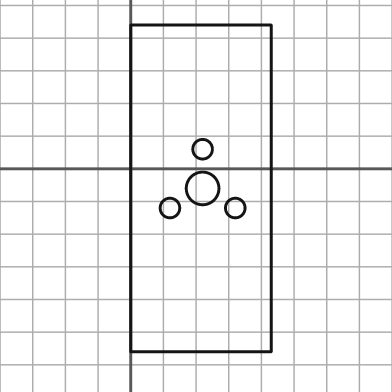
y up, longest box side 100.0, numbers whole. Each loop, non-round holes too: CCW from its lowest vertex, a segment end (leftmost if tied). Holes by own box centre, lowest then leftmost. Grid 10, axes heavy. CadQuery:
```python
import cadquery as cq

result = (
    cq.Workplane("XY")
    .moveTo(0.0, -56.0)
    .lineTo(43.0, -56.0)
    .lineTo(43.0, 44.0)
    .lineTo(0.0, 44.0)
    .close()
    .moveTo(12.0, -12.0)
    .circle(3.0)
    .moveTo(32.0, -12.0)
    .circle(3.0)
    .moveTo(22.0, -6.0)
    .circle(5.0)
    .moveTo(22.0, 6.0)
    .circle(3.0)
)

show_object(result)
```